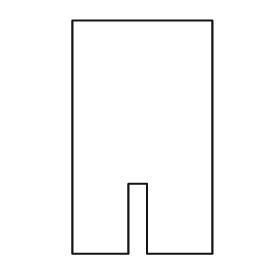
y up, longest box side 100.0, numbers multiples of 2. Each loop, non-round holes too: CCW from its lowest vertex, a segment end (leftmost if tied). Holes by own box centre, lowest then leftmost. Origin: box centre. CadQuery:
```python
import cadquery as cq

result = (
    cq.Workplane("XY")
    .moveTo(-30.0, -50.0)
    .lineTo(-6.0, -50.0)
    .lineTo(-6.0, -20.0)
    .lineTo(2.0, -20.0)
    .lineTo(2.0, -50.0)
    .lineTo(30.0, -50.0)
    .lineTo(30.0, 50.0)
    .lineTo(-30.0, 50.0)
    .close()
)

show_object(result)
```